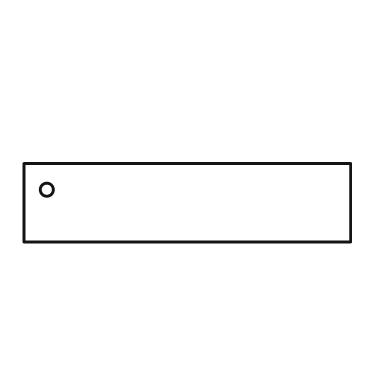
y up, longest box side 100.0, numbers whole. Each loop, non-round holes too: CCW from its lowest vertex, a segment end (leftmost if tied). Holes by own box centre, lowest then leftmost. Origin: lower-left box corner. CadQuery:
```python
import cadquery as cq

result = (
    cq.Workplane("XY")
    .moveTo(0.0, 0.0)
    .lineTo(100.0, 0.0)
    .lineTo(100.0, 24.0)
    .lineTo(0.0, 24.0)
    .close()
    .moveTo(7.0, 16.0)
    .circle(2.0)
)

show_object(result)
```